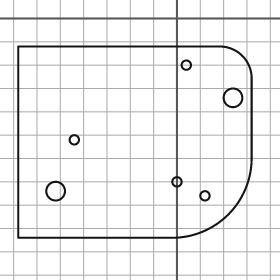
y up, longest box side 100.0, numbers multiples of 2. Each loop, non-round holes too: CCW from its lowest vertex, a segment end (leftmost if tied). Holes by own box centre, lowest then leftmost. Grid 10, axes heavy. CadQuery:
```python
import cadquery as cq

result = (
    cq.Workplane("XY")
    .moveTo(-68.0, -94.0)
    .lineTo(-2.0, -94.0)
    .threePointArc((22.0, -84.0), (32.0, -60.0))
    .lineTo(32.0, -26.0)
    .threePointArc((28.0, -16.0), (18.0, -12.0))
    .lineTo(-68.0, -12.0)
    .close()
    .moveTo(12.0, -76.0)
    .circle(2.0)
    .moveTo(-52.0, -74.0)
    .circle(4.0)
    .moveTo(0.0, -70.0)
    .circle(2.0)
    .moveTo(-44.0, -52.0)
    .circle(2.0)
    .moveTo(24.0, -34.0)
    .circle(4.0)
    .moveTo(4.0, -20.0)
    .circle(2.0)
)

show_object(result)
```